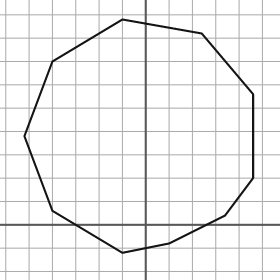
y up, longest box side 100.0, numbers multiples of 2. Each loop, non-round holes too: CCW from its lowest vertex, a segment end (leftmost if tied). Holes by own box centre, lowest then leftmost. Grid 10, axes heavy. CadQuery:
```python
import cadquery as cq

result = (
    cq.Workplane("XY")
    .moveTo(-10.0, -12.0)
    .lineTo(10.0, -8.0)
    .lineTo(34.0, 4.0)
    .lineTo(46.0, 20.0)
    .lineTo(46.0, 56.0)
    .lineTo(24.0, 82.0)
    .lineTo(-10.0, 88.0)
    .lineTo(-40.0, 70.0)
    .lineTo(-52.0, 38.0)
    .lineTo(-40.0, 6.0)
    .close()
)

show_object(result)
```